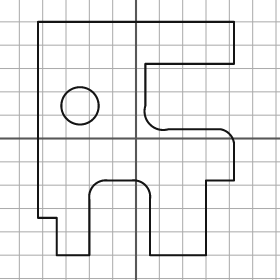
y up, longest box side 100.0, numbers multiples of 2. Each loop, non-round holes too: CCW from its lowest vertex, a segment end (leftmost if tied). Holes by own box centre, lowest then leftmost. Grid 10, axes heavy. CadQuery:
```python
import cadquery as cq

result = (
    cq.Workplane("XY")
    .moveTo(-34.0, -50.0)
    .lineTo(-20.0, -50.0)
    .lineTo(-20.0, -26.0)
    .threePointArc((-18.0, -20.0), (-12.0, -18.0))
    .lineTo(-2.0, -18.0)
    .threePointArc((4.0, -20.0), (6.0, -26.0))
    .lineTo(6.0, -50.0)
    .lineTo(30.0, -50.0)
    .lineTo(30.0, -18.0)
    .lineTo(42.0, -18.0)
    .lineTo(42.0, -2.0)
    .threePointArc((40.0, 2.0), (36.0, 4.0))
    .lineTo(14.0, 4.0)
    .threePointArc((6.0, 6.0), (4.0, 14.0))
    .lineTo(4.0, 32.0)
    .lineTo(42.0, 32.0)
    .lineTo(42.0, 50.0)
    .lineTo(-42.0, 50.0)
    .lineTo(-42.0, -34.0)
    .lineTo(-34.0, -34.0)
    .close()
    .moveTo(-24.0, 14.0)
    .circle(8.0)
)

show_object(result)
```